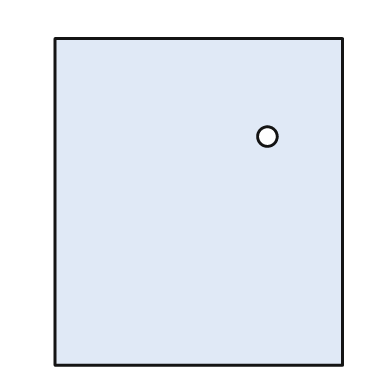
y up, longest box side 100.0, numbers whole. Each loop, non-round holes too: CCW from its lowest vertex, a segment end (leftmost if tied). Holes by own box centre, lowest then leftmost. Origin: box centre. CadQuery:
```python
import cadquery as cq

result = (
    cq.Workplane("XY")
    .moveTo(-44.0, -50.0)
    .lineTo(44.0, -50.0)
    .lineTo(44.0, 50.0)
    .lineTo(-44.0, 50.0)
    .close()
    .moveTo(21.0, 20.0)
    .circle(3.0)
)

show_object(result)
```